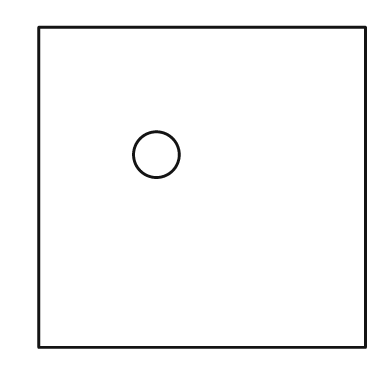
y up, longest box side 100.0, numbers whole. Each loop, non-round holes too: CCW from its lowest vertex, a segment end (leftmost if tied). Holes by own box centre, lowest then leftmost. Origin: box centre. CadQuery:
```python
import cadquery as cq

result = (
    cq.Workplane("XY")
    .moveTo(-50.0, -49.0)
    .lineTo(50.0, -49.0)
    .lineTo(50.0, 49.0)
    .lineTo(-50.0, 49.0)
    .close()
    .moveTo(-14.0, 10.0)
    .circle(7.0)
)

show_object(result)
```